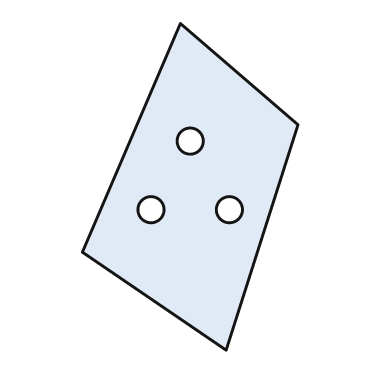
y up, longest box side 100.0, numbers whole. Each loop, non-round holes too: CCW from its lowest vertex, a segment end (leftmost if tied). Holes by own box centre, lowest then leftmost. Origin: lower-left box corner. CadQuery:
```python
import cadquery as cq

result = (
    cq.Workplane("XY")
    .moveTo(44.0, 0.0)
    .lineTo(66.0, 69.0)
    .lineTo(30.0, 100.0)
    .lineTo(0.0, 30.0)
    .close()
    .moveTo(21.0, 43.0)
    .circle(4.0)
    .moveTo(45.0, 43.0)
    .circle(4.0)
    .moveTo(33.0, 64.0)
    .circle(4.0)
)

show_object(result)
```